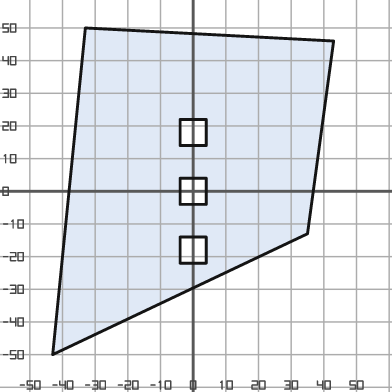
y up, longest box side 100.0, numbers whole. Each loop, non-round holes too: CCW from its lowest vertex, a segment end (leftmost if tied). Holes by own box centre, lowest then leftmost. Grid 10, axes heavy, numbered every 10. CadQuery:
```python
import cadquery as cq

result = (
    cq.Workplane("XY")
    .moveTo(-43.0, -50.0)
    .lineTo(35.0, -13.0)
    .lineTo(43.0, 46.0)
    .lineTo(-33.0, 50.0)
    .close()
    .moveTo(-4.0, -22.0)
    .lineTo(4.0, -22.0)
    .lineTo(4.0, -14.0)
    .lineTo(-4.0, -14.0)
    .close()
    .moveTo(-4.0, -4.0)
    .lineTo(4.0, -4.0)
    .lineTo(4.0, 4.0)
    .lineTo(-4.0, 4.0)
    .close()
    .moveTo(-4.0, 14.0)
    .lineTo(4.0, 14.0)
    .lineTo(4.0, 22.0)
    .lineTo(-4.0, 22.0)
    .close()
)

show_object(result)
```